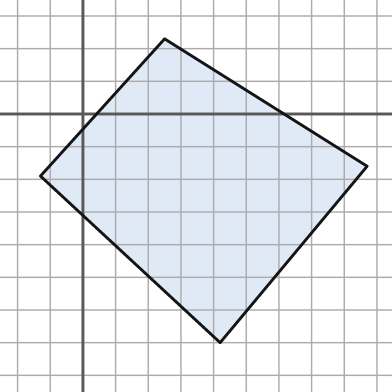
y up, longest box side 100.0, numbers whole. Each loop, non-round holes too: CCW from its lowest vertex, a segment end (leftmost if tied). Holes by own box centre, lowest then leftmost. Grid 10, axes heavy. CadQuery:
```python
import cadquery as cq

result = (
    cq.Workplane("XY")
    .moveTo(42.0, -70.0)
    .lineTo(87.0, -16.0)
    .lineTo(25.0, 23.0)
    .lineTo(-13.0, -19.0)
    .close()
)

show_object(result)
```